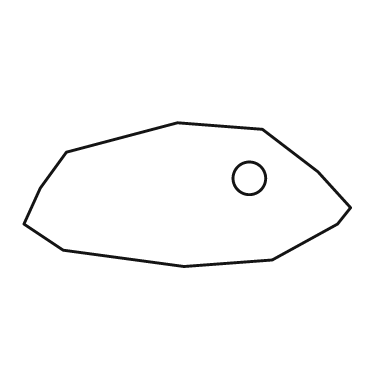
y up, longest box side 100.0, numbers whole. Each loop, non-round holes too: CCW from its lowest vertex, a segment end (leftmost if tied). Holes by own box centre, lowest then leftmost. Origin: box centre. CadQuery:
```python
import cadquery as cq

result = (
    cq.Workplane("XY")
    .moveTo(-1.0, -22.0)
    .lineTo(26.0, -20.0)
    .lineTo(46.0, -9.0)
    .lineTo(50.0, -4.0)
    .lineTo(40.0, 7.0)
    .lineTo(23.0, 20.0)
    .lineTo(-3.0, 22.0)
    .lineTo(-37.0, 13.0)
    .lineTo(-45.0, 2.0)
    .lineTo(-50.0, -9.0)
    .lineTo(-38.0, -17.0)
    .close()
    .moveTo(19.0, 5.0)
    .circle(5.0)
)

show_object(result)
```